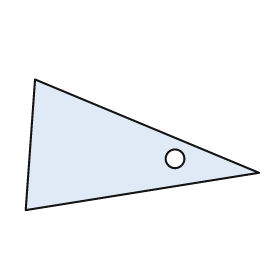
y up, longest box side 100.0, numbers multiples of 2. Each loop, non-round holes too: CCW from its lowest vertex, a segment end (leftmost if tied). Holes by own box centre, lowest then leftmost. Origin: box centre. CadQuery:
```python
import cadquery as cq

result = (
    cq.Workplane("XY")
    .moveTo(-50.0, -28.0)
    .lineTo(50.0, -12.0)
    .lineTo(-46.0, 28.0)
    .close()
    .moveTo(14.0, -6.0)
    .circle(4.0)
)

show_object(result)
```